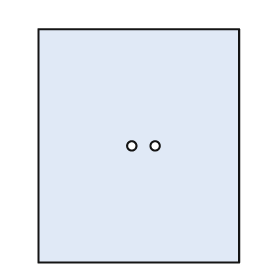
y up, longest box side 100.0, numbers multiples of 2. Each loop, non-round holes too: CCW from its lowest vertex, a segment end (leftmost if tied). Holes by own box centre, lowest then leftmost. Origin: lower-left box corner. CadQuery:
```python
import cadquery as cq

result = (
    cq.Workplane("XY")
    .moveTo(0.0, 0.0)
    .lineTo(86.0, 0.0)
    .lineTo(86.0, 100.0)
    .lineTo(0.0, 100.0)
    .close()
    .moveTo(40.0, 50.0)
    .circle(2.0)
    .moveTo(50.0, 50.0)
    .circle(2.0)
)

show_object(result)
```